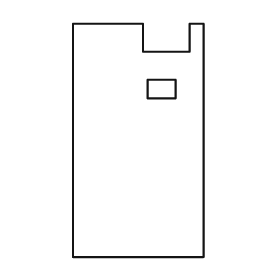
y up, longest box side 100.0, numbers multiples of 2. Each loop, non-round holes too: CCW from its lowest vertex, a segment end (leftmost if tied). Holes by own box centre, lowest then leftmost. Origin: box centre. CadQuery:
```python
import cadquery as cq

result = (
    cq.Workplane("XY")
    .moveTo(-28.0, -50.0)
    .lineTo(28.0, -50.0)
    .lineTo(28.0, 50.0)
    .lineTo(22.0, 50.0)
    .lineTo(22.0, 38.0)
    .lineTo(2.0, 38.0)
    .lineTo(2.0, 50.0)
    .lineTo(-28.0, 50.0)
    .close()
    .moveTo(4.0, 18.0)
    .lineTo(16.0, 18.0)
    .lineTo(16.0, 26.0)
    .lineTo(4.0, 26.0)
    .close()
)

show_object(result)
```